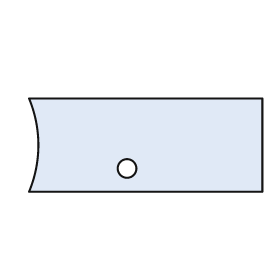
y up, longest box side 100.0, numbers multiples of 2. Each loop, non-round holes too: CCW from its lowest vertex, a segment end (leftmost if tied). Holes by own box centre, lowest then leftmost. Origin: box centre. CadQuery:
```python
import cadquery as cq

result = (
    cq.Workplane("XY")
    .moveTo(-50.0, -20.0)
    .lineTo(50.0, -20.0)
    .lineTo(50.0, 20.0)
    .lineTo(-50.0, 20.0)
    .threePointArc((-46.0, 0.0), (-50.0, -20.0))
    .close()
    .moveTo(-8.0, -10.0)
    .circle(4.0)
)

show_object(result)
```